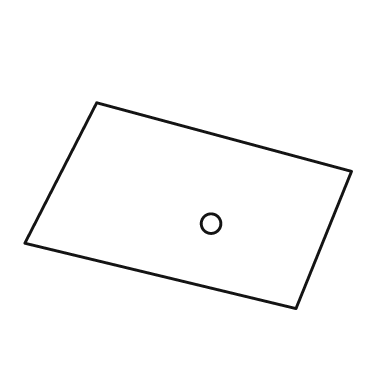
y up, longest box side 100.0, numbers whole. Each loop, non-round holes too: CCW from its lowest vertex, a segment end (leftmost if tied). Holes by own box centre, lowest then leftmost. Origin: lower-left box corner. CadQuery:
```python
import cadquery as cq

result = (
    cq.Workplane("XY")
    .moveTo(83.0, 0.0)
    .lineTo(100.0, 42.0)
    .lineTo(22.0, 63.0)
    .lineTo(0.0, 20.0)
    .close()
    .moveTo(57.0, 26.0)
    .circle(3.0)
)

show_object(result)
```